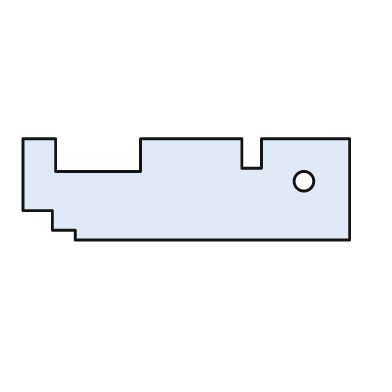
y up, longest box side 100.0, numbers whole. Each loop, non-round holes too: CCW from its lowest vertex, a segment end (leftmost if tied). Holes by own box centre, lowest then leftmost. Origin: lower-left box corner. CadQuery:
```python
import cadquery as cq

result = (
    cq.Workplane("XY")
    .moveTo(16.0, 0.0)
    .lineTo(100.0, 0.0)
    .lineTo(100.0, 31.0)
    .lineTo(73.0, 31.0)
    .lineTo(73.0, 22.0)
    .lineTo(67.0, 22.0)
    .lineTo(67.0, 31.0)
    .lineTo(36.0, 31.0)
    .lineTo(36.0, 21.0)
    .lineTo(10.0, 21.0)
    .lineTo(10.0, 31.0)
    .lineTo(0.0, 31.0)
    .lineTo(0.0, 9.0)
    .lineTo(9.0, 9.0)
    .lineTo(9.0, 3.0)
    .lineTo(16.0, 3.0)
    .close()
    .moveTo(86.0, 18.0)
    .circle(3.0)
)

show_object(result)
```